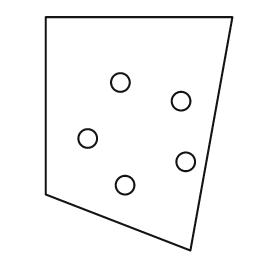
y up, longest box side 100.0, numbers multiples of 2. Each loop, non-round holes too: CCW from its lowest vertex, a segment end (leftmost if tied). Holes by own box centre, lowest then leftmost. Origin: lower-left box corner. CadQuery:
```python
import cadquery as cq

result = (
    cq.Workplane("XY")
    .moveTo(62.0, 0.0)
    .lineTo(80.0, 100.0)
    .lineTo(0.0, 100.0)
    .lineTo(0.0, 24.0)
    .close()
    .moveTo(34.0, 28.0)
    .circle(4.0)
    .moveTo(60.0, 38.0)
    .circle(4.0)
    .moveTo(18.0, 48.0)
    .circle(4.0)
    .moveTo(58.0, 64.0)
    .circle(4.0)
    .moveTo(32.0, 72.0)
    .circle(4.0)
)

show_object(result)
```